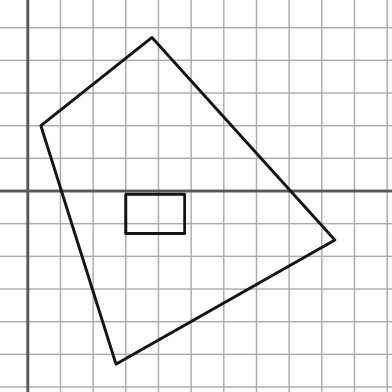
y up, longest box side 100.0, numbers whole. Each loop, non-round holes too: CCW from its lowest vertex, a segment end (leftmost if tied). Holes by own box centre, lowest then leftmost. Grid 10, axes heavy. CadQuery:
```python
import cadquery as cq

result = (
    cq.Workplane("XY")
    .moveTo(27.0, -53.0)
    .lineTo(94.0, -15.0)
    .lineTo(38.0, 47.0)
    .lineTo(4.0, 20.0)
    .close()
    .moveTo(30.0, -13.0)
    .lineTo(48.0, -13.0)
    .lineTo(48.0, -1.0)
    .lineTo(30.0, -1.0)
    .close()
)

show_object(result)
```